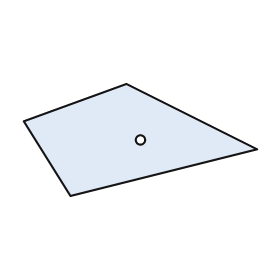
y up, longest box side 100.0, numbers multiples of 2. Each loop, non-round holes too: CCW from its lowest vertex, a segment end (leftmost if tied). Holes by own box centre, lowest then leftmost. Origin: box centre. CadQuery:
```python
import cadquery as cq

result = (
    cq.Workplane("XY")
    .moveTo(-30.0, -24.0)
    .lineTo(50.0, -4.0)
    .lineTo(-6.0, 24.0)
    .lineTo(-50.0, 8.0)
    .close()
    .moveTo(0.0, 0.0)
    .circle(2.0)
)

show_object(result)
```